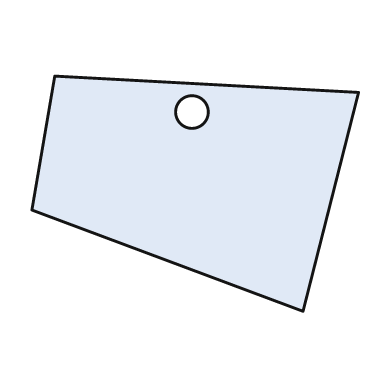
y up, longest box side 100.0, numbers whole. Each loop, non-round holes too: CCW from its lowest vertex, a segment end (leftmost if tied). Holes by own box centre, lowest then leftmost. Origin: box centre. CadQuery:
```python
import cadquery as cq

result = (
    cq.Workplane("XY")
    .moveTo(33.0, -36.0)
    .lineTo(50.0, 31.0)
    .lineTo(-43.0, 36.0)
    .lineTo(-50.0, -5.0)
    .close()
    .moveTo(-1.0, 25.0)
    .circle(5.0)
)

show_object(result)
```